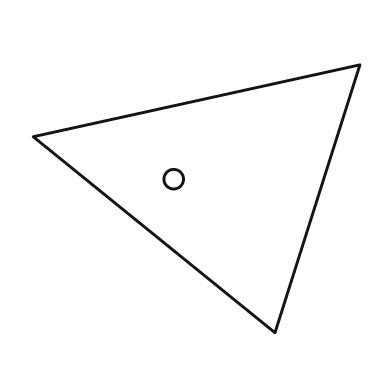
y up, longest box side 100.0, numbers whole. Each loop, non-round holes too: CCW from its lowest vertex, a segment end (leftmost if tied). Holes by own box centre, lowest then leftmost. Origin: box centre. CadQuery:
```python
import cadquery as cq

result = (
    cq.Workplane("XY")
    .moveTo(24.0, -41.0)
    .lineTo(50.0, 41.0)
    .lineTo(-50.0, 19.0)
    .close()
    .moveTo(-7.0, 6.0)
    .circle(3.0)
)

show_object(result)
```